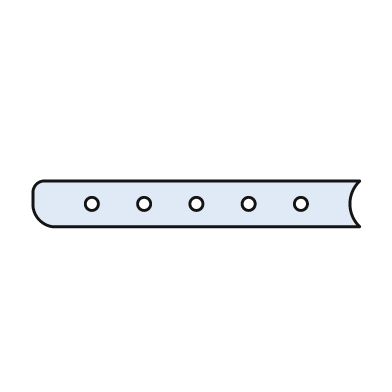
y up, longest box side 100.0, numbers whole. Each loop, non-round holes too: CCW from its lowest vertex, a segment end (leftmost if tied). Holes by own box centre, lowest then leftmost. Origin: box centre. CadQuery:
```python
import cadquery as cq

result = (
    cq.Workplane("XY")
    .moveTo(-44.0, -7.0)
    .lineTo(50.0, -7.0)
    .threePointArc((47.0, 0.0), (50.0, 7.0))
    .lineTo(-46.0, 7.0)
    .threePointArc((-49.0, 6.0), (-50.0, 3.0))
    .lineTo(-50.0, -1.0)
    .threePointArc((-48.0, -5.0), (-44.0, -7.0))
    .close()
    .moveTo(-32.0, 0.0)
    .circle(2.0)
    .moveTo(-16.0, 0.0)
    .circle(2.0)
    .moveTo(0.0, 0.0)
    .circle(2.0)
    .moveTo(16.0, 0.0)
    .circle(2.0)
    .moveTo(32.0, 0.0)
    .circle(2.0)
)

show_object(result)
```